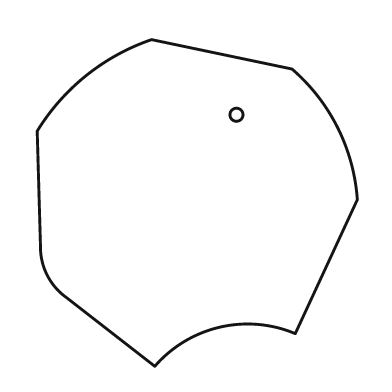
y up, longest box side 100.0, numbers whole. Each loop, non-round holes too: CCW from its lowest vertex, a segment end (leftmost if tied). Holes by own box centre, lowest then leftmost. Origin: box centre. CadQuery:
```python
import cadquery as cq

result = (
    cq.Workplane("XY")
    .moveTo(-13.0, -50.0)
    .threePointArc((7.0, -38.0), (30.0, -40.0))
    .lineTo(49.0, 1.0)
    .threePointArc((43.0, 23.0), (29.0, 41.0))
    .lineTo(-14.0, 50.0)
    .threePointArc((-34.0, 39.0), (-49.0, 22.0))
    .lineTo(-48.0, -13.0)
    .threePointArc((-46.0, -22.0), (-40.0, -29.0))
    .close()
    .moveTo(12.0, 27.0)
    .circle(2.0)
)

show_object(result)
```